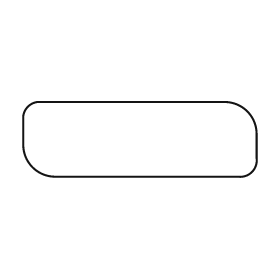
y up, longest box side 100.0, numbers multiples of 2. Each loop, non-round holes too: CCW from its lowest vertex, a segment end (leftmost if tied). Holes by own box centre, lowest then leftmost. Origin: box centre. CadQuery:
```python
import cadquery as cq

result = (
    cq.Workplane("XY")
    .moveTo(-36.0, -16.0)
    .lineTo(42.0, -16.0)
    .threePointArc((48.0, -14.0), (50.0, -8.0))
    .lineTo(50.0, 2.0)
    .threePointArc((46.0, 12.0), (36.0, 16.0))
    .lineTo(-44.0, 16.0)
    .threePointArc((-48.0, 14.0), (-50.0, 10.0))
    .lineTo(-50.0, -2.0)
    .threePointArc((-46.0, -12.0), (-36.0, -16.0))
    .close()
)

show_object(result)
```